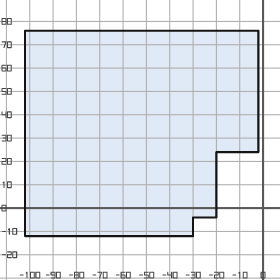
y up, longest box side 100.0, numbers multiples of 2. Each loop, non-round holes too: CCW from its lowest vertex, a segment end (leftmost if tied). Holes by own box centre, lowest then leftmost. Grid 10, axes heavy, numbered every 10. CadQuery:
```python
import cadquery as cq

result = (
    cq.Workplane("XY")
    .moveTo(-102.0, -12.0)
    .lineTo(-30.0, -12.0)
    .lineTo(-30.0, -4.0)
    .lineTo(-20.0, -4.0)
    .lineTo(-20.0, 24.0)
    .lineTo(-2.0, 24.0)
    .lineTo(-2.0, 76.0)
    .lineTo(-102.0, 76.0)
    .close()
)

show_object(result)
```